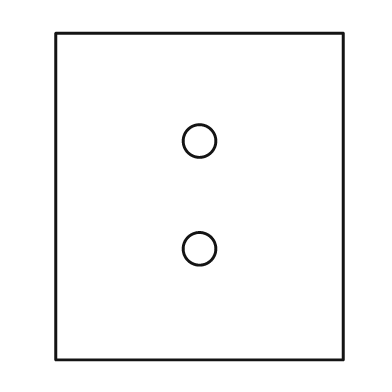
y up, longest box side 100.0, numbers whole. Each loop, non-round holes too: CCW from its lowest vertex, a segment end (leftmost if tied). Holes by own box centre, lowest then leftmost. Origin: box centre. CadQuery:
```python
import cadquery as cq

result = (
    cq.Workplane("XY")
    .moveTo(-44.0, -50.0)
    .lineTo(44.0, -50.0)
    .lineTo(44.0, 50.0)
    .lineTo(-44.0, 50.0)
    .close()
    .moveTo(0.0, -16.0)
    .circle(5.0)
    .moveTo(0.0, 17.0)
    .circle(5.0)
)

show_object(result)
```